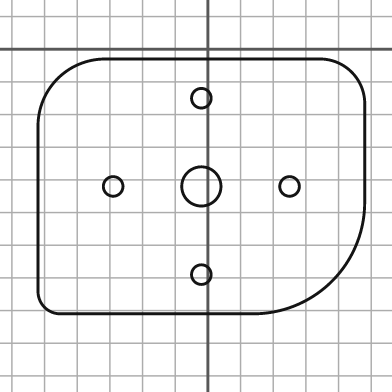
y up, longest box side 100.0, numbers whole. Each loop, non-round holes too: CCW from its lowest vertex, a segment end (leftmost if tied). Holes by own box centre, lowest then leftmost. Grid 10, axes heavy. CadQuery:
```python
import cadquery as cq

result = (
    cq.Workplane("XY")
    .moveTo(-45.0, -81.0)
    .lineTo(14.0, -81.0)
    .threePointArc((38.0, -71.0), (48.0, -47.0))
    .lineTo(48.0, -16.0)
    .threePointArc((44.0, -7.0), (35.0, -3.0))
    .lineTo(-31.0, -3.0)
    .threePointArc((-46.0, -9.0), (-52.0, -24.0))
    .lineTo(-52.0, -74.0)
    .threePointArc((-50.0, -79.0), (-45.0, -81.0))
    .close()
    .moveTo(-2.0, -69.0)
    .circle(3.0)
    .moveTo(-29.0, -42.0)
    .circle(3.0)
    .moveTo(-2.0, -42.0)
    .circle(6.0)
    .moveTo(25.0, -42.0)
    .circle(3.0)
    .moveTo(-2.0, -15.0)
    .circle(3.0)
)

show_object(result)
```